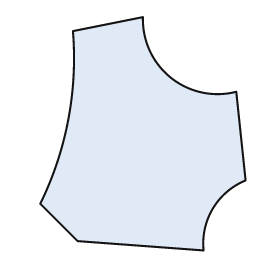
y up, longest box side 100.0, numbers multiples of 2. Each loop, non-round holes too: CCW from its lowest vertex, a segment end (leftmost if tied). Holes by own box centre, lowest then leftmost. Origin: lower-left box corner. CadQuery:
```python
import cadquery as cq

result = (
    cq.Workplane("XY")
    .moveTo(70.0, 0.0)
    .threePointArc((74.0, 18.0), (88.0, 30.0))
    .lineTo(84.0, 68.0)
    .threePointArc((56.0, 74.0), (44.0, 100.0))
    .lineTo(14.0, 94.0)
    .threePointArc((12.0, 56.0), (0.0, 20.0))
    .lineTo(16.0, 4.0)
    .close()
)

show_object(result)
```